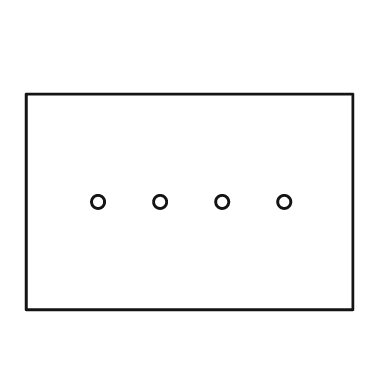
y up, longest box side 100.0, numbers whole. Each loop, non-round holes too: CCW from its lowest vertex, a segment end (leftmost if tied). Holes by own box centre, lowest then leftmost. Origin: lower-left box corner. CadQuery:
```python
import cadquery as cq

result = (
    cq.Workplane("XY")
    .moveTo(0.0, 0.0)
    .lineTo(100.0, 0.0)
    .lineTo(100.0, 66.0)
    .lineTo(0.0, 66.0)
    .close()
    .moveTo(22.0, 33.0)
    .circle(2.0)
    .moveTo(41.0, 33.0)
    .circle(2.0)
    .moveTo(60.0, 33.0)
    .circle(2.0)
    .moveTo(79.0, 33.0)
    .circle(2.0)
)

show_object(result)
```